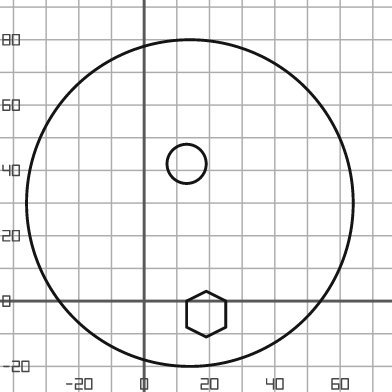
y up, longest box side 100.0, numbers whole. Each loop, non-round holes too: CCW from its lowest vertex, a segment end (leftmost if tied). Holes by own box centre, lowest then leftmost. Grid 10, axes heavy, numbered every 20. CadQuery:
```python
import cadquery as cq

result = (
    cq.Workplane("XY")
    .moveTo(14.0, 30.0)
    .circle(50.0)
    .moveTo(19.0, -11.0)
    .lineTo(25.0, -8.0)
    .lineTo(25.0, 0.0)
    .lineTo(19.0, 3.0)
    .lineTo(13.0, 0.0)
    .lineTo(13.0, -8.0)
    .close()
    .moveTo(13.0, 42.0)
    .circle(6.0)
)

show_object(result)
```